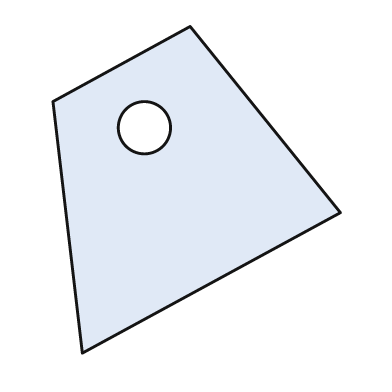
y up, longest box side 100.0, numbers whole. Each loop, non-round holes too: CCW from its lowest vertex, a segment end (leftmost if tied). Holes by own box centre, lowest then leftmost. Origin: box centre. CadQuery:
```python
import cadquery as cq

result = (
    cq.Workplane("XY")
    .moveTo(-35.0, -50.0)
    .lineTo(44.0, -7.0)
    .lineTo(-2.0, 50.0)
    .lineTo(-44.0, 27.0)
    .close()
    .moveTo(-16.0, 19.0)
    .circle(8.0)
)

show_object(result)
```